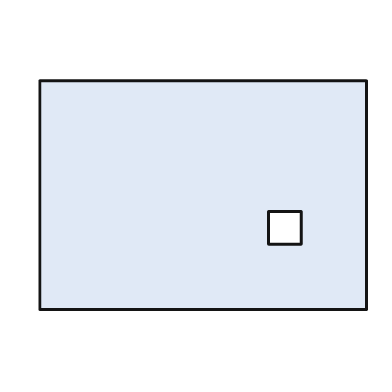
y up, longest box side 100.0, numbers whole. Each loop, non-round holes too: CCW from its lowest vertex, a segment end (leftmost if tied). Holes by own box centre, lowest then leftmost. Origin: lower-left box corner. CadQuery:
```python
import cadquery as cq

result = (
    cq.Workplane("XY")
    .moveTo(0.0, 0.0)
    .lineTo(100.0, 0.0)
    .lineTo(100.0, 70.0)
    .lineTo(0.0, 70.0)
    .close()
    .moveTo(70.0, 20.0)
    .lineTo(80.0, 20.0)
    .lineTo(80.0, 30.0)
    .lineTo(70.0, 30.0)
    .close()
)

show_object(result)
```